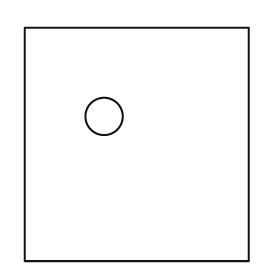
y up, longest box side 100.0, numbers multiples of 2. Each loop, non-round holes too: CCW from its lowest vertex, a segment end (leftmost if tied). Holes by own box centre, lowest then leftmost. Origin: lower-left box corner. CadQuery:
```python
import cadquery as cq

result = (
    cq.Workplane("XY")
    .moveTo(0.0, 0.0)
    .lineTo(96.0, 0.0)
    .lineTo(96.0, 100.0)
    .lineTo(0.0, 100.0)
    .close()
    .moveTo(34.0, 62.0)
    .circle(8.0)
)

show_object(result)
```